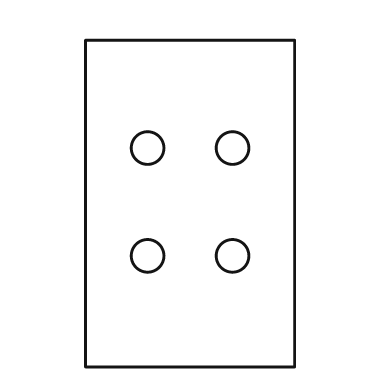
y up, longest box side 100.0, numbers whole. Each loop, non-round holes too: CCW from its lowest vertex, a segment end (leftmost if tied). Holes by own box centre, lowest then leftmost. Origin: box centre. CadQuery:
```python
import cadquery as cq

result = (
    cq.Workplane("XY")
    .moveTo(-32.0, -50.0)
    .lineTo(32.0, -50.0)
    .lineTo(32.0, 50.0)
    .lineTo(-32.0, 50.0)
    .close()
    .moveTo(-13.0, -16.0)
    .circle(5.0)
    .moveTo(13.0, -16.0)
    .circle(5.0)
    .moveTo(-13.0, 17.0)
    .circle(5.0)
    .moveTo(13.0, 17.0)
    .circle(5.0)
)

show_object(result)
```